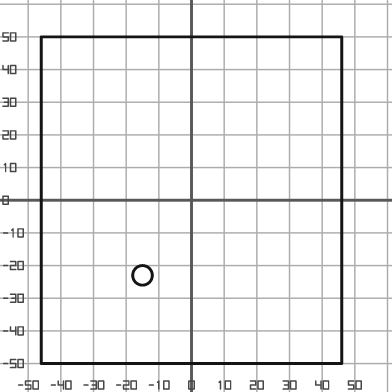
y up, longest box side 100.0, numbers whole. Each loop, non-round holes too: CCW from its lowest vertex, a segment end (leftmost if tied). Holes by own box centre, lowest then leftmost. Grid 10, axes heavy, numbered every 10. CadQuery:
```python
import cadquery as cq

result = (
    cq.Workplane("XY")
    .moveTo(-46.0, -50.0)
    .lineTo(46.0, -50.0)
    .lineTo(46.0, 50.0)
    .lineTo(-46.0, 50.0)
    .close()
    .moveTo(-15.0, -23.0)
    .circle(3.0)
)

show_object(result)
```